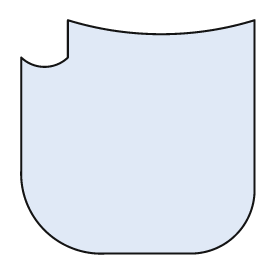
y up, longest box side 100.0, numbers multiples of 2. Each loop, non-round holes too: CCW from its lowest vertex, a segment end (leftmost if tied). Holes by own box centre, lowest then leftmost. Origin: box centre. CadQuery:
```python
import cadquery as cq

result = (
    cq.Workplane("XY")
    .moveTo(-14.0, -50.0)
    .lineTo(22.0, -50.0)
    .threePointArc((42.0, -42.0), (50.0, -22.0))
    .lineTo(50.0, 50.0)
    .threePointArc((10.0, 44.0), (-30.0, 50.0))
    .lineTo(-30.0, 34.0)
    .threePointArc((-40.0, 30.0), (-50.0, 34.0))
    .lineTo(-50.0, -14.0)
    .threePointArc((-40.0, -40.0), (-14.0, -50.0))
    .close()
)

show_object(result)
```